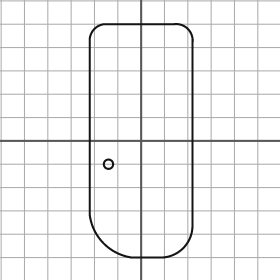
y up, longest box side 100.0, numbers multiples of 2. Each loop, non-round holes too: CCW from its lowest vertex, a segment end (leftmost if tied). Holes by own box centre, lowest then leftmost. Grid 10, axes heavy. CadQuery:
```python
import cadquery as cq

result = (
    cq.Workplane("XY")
    .moveTo(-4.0, -50.0)
    .lineTo(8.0, -50.0)
    .threePointArc((18.0, -46.0), (22.0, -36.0))
    .lineTo(22.0, 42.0)
    .threePointArc((20.0, 48.0), (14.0, 50.0))
    .lineTo(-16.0, 50.0)
    .threePointArc((-20.0, 48.0), (-22.0, 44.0))
    .lineTo(-22.0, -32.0)
    .threePointArc((-16.0, -44.0), (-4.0, -50.0))
    .close()
    .moveTo(-14.0, -10.0)
    .circle(2.0)
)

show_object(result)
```